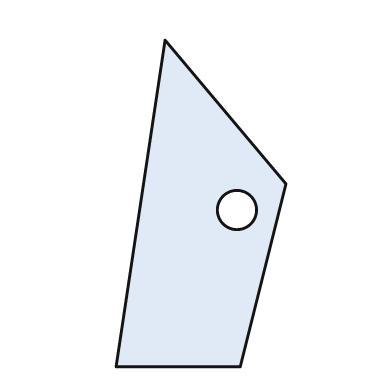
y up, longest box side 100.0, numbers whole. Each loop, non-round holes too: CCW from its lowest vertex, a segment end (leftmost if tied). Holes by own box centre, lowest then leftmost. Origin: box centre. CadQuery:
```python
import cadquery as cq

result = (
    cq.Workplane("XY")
    .moveTo(-26.0, -50.0)
    .lineTo(12.0, -50.0)
    .lineTo(26.0, 6.0)
    .lineTo(-11.0, 50.0)
    .close()
    .moveTo(11.0, -2.0)
    .circle(6.0)
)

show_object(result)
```